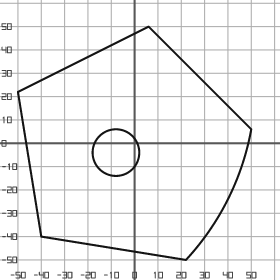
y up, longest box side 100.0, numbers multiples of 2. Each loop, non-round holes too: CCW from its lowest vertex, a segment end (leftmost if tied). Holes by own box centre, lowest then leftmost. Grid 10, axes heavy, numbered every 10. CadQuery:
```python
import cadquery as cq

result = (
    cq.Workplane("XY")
    .moveTo(22.0, -50.0)
    .threePointArc((40.0, -24.0), (50.0, 6.0))
    .lineTo(6.0, 50.0)
    .lineTo(-50.0, 22.0)
    .lineTo(-40.0, -40.0)
    .close()
    .moveTo(-8.0, -4.0)
    .circle(10.0)
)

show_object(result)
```